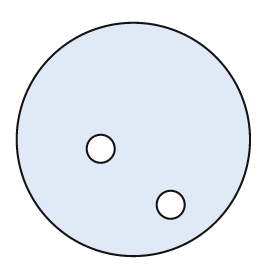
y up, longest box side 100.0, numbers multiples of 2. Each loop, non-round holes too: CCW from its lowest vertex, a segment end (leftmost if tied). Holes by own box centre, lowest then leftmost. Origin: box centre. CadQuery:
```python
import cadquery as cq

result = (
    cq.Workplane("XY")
    .moveTo(0.0, 0.0)
    .circle(50.0)
    .moveTo(16.0, -28.0)
    .circle(6.0)
    .moveTo(-14.0, -4.0)
    .circle(6.0)
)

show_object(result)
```